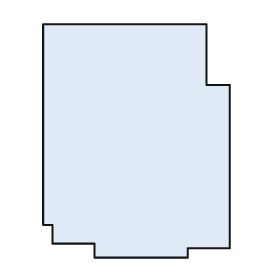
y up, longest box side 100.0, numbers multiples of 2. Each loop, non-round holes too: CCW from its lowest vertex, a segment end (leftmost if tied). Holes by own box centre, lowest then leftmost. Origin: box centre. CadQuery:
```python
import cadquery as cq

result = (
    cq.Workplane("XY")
    .moveTo(-18.0, -50.0)
    .lineTo(22.0, -50.0)
    .lineTo(22.0, -46.0)
    .lineTo(40.0, -46.0)
    .lineTo(40.0, 24.0)
    .lineTo(30.0, 24.0)
    .lineTo(30.0, 50.0)
    .lineTo(-40.0, 50.0)
    .lineTo(-40.0, -36.0)
    .lineTo(-36.0, -36.0)
    .lineTo(-36.0, -44.0)
    .lineTo(-18.0, -44.0)
    .close()
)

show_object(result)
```